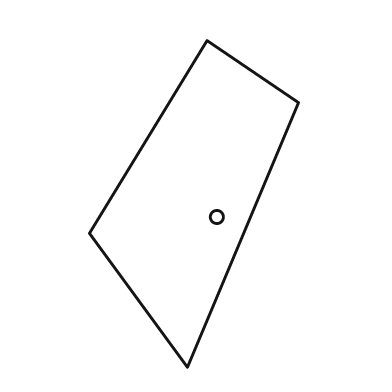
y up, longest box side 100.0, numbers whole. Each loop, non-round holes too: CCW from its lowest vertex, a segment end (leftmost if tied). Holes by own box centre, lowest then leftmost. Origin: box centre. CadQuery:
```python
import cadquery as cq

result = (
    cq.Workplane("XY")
    .moveTo(-2.0, -50.0)
    .lineTo(32.0, 31.0)
    .lineTo(4.0, 50.0)
    .lineTo(-32.0, -9.0)
    .close()
    .moveTo(7.0, -4.0)
    .circle(2.0)
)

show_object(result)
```